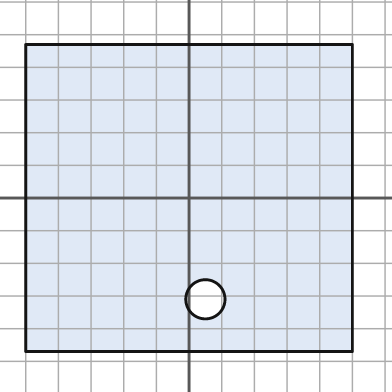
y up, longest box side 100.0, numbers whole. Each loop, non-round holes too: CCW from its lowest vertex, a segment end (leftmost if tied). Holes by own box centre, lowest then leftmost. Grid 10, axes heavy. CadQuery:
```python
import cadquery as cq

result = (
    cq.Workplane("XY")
    .moveTo(-50.0, -47.0)
    .lineTo(50.0, -47.0)
    .lineTo(50.0, 47.0)
    .lineTo(-50.0, 47.0)
    .close()
    .moveTo(5.0, -31.0)
    .circle(6.0)
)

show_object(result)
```